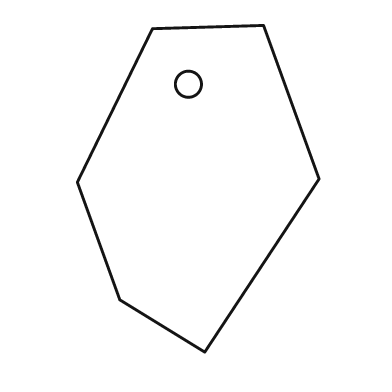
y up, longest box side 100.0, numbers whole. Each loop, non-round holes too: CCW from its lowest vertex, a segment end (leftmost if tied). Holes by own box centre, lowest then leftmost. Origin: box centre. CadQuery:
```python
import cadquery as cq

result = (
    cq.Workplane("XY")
    .moveTo(2.0, -50.0)
    .lineTo(37.0, 3.0)
    .lineTo(20.0, 50.0)
    .lineTo(-14.0, 49.0)
    .lineTo(-37.0, 2.0)
    .lineTo(-24.0, -34.0)
    .close()
    .moveTo(-3.0, 32.0)
    .circle(4.0)
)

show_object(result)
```